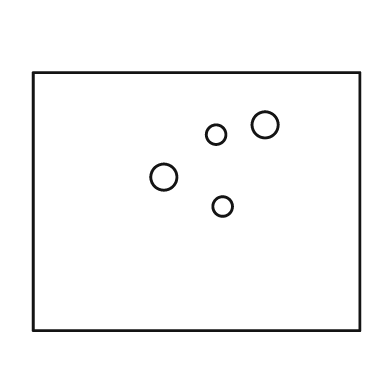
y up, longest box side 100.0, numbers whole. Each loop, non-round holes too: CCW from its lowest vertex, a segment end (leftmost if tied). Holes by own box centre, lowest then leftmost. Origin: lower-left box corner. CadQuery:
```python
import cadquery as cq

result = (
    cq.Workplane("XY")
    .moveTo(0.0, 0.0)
    .lineTo(100.0, 0.0)
    .lineTo(100.0, 79.0)
    .lineTo(0.0, 79.0)
    .close()
    .moveTo(58.0, 38.0)
    .circle(3.0)
    .moveTo(40.0, 47.0)
    .circle(4.0)
    .moveTo(56.0, 60.0)
    .circle(3.0)
    .moveTo(71.0, 63.0)
    .circle(4.0)
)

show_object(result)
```